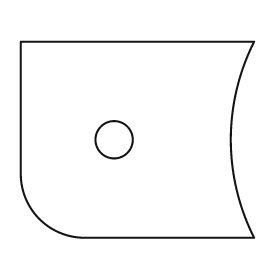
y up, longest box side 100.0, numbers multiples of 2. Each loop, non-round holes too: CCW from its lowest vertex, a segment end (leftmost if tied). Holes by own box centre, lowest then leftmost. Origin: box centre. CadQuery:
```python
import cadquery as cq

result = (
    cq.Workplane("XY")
    .moveTo(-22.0, -42.0)
    .lineTo(50.0, -42.0)
    .threePointArc((40.0, 0.0), (50.0, 42.0))
    .lineTo(-50.0, 42.0)
    .lineTo(-50.0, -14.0)
    .threePointArc((-42.0, -34.0), (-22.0, -42.0))
    .close()
    .moveTo(-10.0, 0.0)
    .circle(8.0)
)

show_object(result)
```